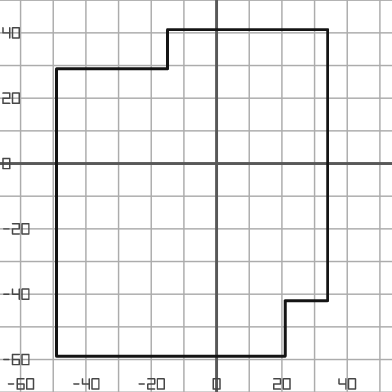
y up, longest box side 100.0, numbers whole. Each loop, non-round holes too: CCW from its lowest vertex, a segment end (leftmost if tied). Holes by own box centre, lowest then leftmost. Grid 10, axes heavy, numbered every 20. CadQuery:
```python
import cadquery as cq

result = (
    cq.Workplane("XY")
    .moveTo(-49.0, -59.0)
    .lineTo(21.0, -59.0)
    .lineTo(21.0, -42.0)
    .lineTo(34.0, -42.0)
    .lineTo(34.0, 41.0)
    .lineTo(-15.0, 41.0)
    .lineTo(-15.0, 29.0)
    .lineTo(-49.0, 29.0)
    .close()
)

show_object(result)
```